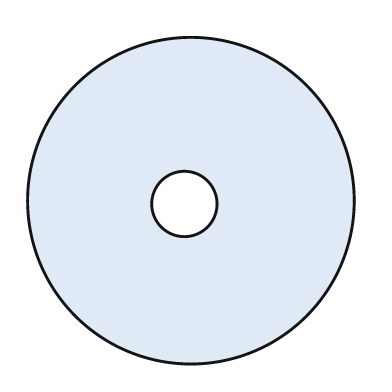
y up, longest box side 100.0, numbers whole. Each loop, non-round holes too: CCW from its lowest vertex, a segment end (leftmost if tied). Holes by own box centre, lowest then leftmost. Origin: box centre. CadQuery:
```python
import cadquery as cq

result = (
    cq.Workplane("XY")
    .moveTo(0.0, 0.0)
    .circle(50.0)
    .moveTo(-2.0, -1.0)
    .circle(10.0)
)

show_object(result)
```